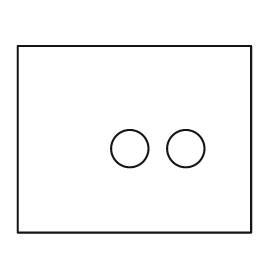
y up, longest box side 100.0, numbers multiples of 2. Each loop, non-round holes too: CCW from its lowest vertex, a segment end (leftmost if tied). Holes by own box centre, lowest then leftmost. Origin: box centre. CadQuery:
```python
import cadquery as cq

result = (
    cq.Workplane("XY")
    .moveTo(-50.0, -40.0)
    .lineTo(50.0, -40.0)
    .lineTo(50.0, 40.0)
    .lineTo(-50.0, 40.0)
    .close()
    .moveTo(-2.0, -4.0)
    .circle(8.0)
    .moveTo(22.0, -4.0)
    .circle(8.0)
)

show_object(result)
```